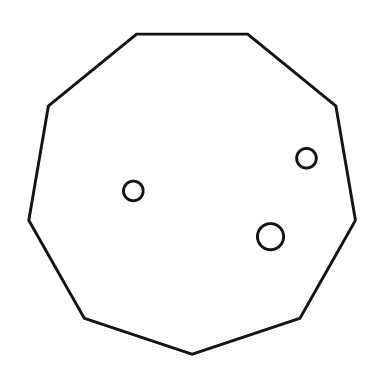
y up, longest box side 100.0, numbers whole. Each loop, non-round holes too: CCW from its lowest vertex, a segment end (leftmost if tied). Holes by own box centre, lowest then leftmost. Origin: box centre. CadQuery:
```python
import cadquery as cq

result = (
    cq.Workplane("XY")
    .moveTo(0.0, -49.0)
    .lineTo(33.0, -38.0)
    .lineTo(50.0, -8.0)
    .lineTo(44.0, 27.0)
    .lineTo(17.0, 49.0)
    .lineTo(-17.0, 49.0)
    .lineTo(-44.0, 27.0)
    .lineTo(-50.0, -8.0)
    .lineTo(-33.0, -38.0)
    .close()
    .moveTo(24.0, -13.0)
    .circle(4.0)
    .moveTo(-18.0, 1.0)
    .circle(3.0)
    .moveTo(35.0, 11.0)
    .circle(3.0)
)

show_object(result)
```